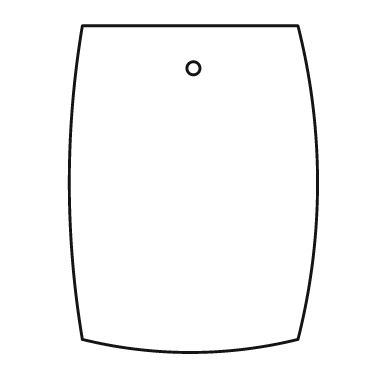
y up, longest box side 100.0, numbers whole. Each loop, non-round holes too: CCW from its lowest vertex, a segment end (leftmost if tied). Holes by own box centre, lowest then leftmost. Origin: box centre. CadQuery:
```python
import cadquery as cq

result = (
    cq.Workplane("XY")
    .moveTo(-34.0, -46.0)
    .threePointArc((-1.0, -50.0), (32.0, -46.0))
    .threePointArc((38.0, 2.0), (32.0, 50.0))
    .lineTo(-34.0, 50.0)
    .threePointArc((-38.0, 2.0), (-34.0, -46.0))
    .close()
    .moveTo(0.0, 37.0)
    .circle(2.0)
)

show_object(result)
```